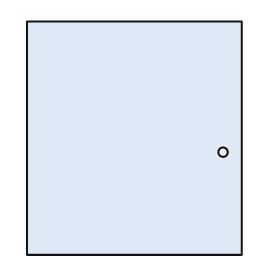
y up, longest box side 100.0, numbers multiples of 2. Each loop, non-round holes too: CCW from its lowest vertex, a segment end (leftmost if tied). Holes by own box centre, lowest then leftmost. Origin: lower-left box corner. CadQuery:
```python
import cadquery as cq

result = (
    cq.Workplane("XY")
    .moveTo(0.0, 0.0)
    .lineTo(92.0, 0.0)
    .lineTo(92.0, 100.0)
    .lineTo(0.0, 100.0)
    .close()
    .moveTo(84.0, 44.0)
    .circle(2.0)
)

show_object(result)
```